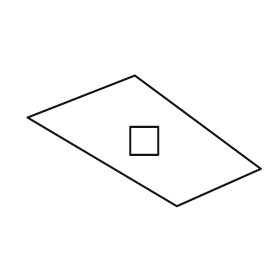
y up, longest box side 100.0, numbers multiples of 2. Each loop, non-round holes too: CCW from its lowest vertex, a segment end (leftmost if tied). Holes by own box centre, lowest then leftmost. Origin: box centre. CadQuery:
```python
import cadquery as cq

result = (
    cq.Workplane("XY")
    .moveTo(14.0, -28.0)
    .lineTo(50.0, -12.0)
    .lineTo(-4.0, 28.0)
    .lineTo(-50.0, 10.0)
    .close()
    .moveTo(-6.0, -6.0)
    .lineTo(6.0, -6.0)
    .lineTo(6.0, 6.0)
    .lineTo(-6.0, 6.0)
    .close()
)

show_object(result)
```